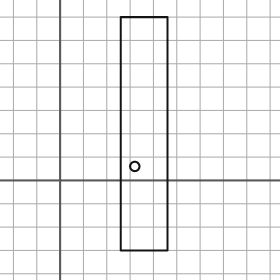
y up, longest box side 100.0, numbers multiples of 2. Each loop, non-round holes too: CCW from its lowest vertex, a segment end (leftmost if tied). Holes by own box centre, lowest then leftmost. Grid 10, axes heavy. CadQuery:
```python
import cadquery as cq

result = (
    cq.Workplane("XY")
    .moveTo(26.0, -30.0)
    .lineTo(46.0, -30.0)
    .lineTo(46.0, 70.0)
    .lineTo(26.0, 70.0)
    .close()
    .moveTo(32.0, 6.0)
    .circle(2.0)
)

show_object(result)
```